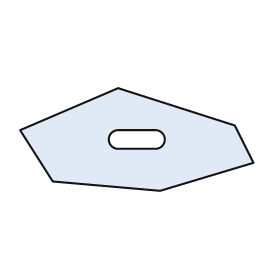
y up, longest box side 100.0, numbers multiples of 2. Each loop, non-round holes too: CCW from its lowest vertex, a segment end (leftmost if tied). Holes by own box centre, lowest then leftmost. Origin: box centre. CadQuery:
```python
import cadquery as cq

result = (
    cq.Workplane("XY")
    .moveTo(10.0, -22.0)
    .lineTo(50.0, -10.0)
    .lineTo(42.0, 6.0)
    .lineTo(-8.0, 22.0)
    .lineTo(-50.0, 4.0)
    .lineTo(-36.0, -18.0)
    .close()
    .moveTo(-8.0, -4.0)
    .lineTo(8.0, -4.0)
    .threePointArc((12.0, 0.0), (8.0, 4.0))
    .lineTo(-8.0, 4.0)
    .threePointArc((-12.0, 0.0), (-8.0, -4.0))
    .close()
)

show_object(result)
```